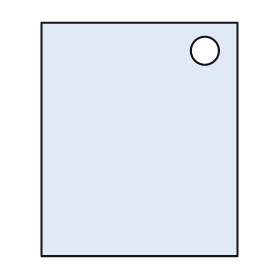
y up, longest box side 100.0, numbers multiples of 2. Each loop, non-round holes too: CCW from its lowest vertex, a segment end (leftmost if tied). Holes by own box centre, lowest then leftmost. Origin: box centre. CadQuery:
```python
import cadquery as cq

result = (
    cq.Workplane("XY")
    .moveTo(-42.0, -50.0)
    .lineTo(42.0, -50.0)
    .lineTo(42.0, 50.0)
    .lineTo(-42.0, 50.0)
    .close()
    .moveTo(28.0, 38.0)
    .circle(6.0)
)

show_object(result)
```